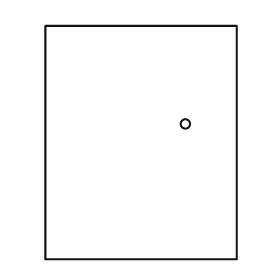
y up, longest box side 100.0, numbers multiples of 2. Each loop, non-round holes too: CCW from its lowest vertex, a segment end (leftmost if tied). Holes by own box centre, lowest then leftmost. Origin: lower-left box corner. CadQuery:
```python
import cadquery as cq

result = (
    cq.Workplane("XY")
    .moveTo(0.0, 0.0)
    .lineTo(82.0, 0.0)
    .lineTo(82.0, 100.0)
    .lineTo(0.0, 100.0)
    .close()
    .moveTo(60.0, 58.0)
    .circle(2.0)
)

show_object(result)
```